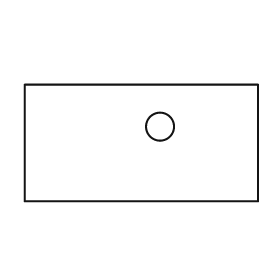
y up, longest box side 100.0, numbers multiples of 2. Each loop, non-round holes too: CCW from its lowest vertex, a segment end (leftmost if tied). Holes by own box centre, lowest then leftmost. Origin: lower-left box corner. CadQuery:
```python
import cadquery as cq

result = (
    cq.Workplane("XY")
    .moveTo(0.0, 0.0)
    .lineTo(100.0, 0.0)
    .lineTo(100.0, 50.0)
    .lineTo(0.0, 50.0)
    .close()
    .moveTo(58.0, 32.0)
    .circle(6.0)
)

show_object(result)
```